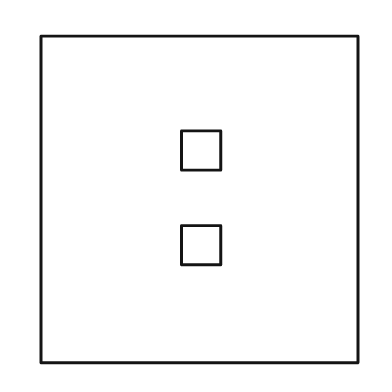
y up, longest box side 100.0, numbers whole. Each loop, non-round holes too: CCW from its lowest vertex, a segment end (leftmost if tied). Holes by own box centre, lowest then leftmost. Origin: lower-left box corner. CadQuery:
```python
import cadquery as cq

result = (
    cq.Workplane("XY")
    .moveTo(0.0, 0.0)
    .lineTo(97.0, 0.0)
    .lineTo(97.0, 100.0)
    .lineTo(0.0, 100.0)
    .close()
    .moveTo(43.0, 30.0)
    .lineTo(55.0, 30.0)
    .lineTo(55.0, 42.0)
    .lineTo(43.0, 42.0)
    .close()
    .moveTo(43.0, 59.0)
    .lineTo(55.0, 59.0)
    .lineTo(55.0, 71.0)
    .lineTo(43.0, 71.0)
    .close()
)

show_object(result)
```